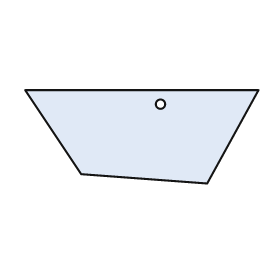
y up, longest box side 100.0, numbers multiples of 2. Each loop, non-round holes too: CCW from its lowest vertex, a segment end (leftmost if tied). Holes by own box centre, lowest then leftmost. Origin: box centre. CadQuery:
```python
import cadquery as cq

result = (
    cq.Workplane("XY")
    .moveTo(28.0, -20.0)
    .lineTo(50.0, 20.0)
    .lineTo(-50.0, 20.0)
    .lineTo(-26.0, -16.0)
    .close()
    .moveTo(8.0, 14.0)
    .circle(2.0)
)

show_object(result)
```